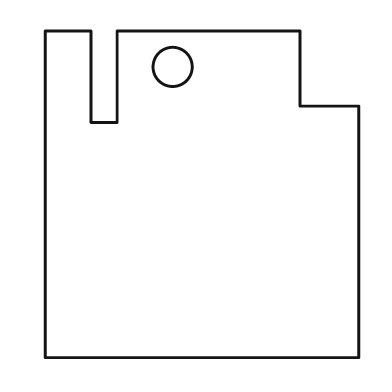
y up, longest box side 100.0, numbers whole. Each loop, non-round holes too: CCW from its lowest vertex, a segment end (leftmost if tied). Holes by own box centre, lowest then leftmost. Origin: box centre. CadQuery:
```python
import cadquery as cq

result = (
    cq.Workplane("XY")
    .moveTo(-48.0, -50.0)
    .lineTo(48.0, -50.0)
    .lineTo(48.0, 27.0)
    .lineTo(30.0, 27.0)
    .lineTo(30.0, 50.0)
    .lineTo(-26.0, 50.0)
    .lineTo(-26.0, 22.0)
    .lineTo(-34.0, 22.0)
    .lineTo(-34.0, 50.0)
    .lineTo(-48.0, 50.0)
    .close()
    .moveTo(-9.0, 39.0)
    .circle(6.0)
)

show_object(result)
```